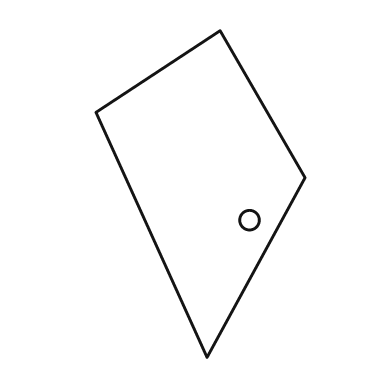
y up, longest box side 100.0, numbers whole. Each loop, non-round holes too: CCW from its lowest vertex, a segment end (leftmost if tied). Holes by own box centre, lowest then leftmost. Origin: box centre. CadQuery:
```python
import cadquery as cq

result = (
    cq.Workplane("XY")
    .moveTo(2.0, -50.0)
    .lineTo(32.0, 5.0)
    .lineTo(6.0, 50.0)
    .lineTo(-32.0, 25.0)
    .close()
    .moveTo(15.0, -8.0)
    .circle(3.0)
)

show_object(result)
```